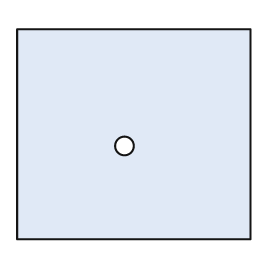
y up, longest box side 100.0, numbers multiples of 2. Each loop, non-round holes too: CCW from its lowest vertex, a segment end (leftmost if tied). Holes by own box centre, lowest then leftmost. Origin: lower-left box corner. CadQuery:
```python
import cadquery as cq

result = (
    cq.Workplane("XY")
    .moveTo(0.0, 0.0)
    .lineTo(100.0, 0.0)
    .lineTo(100.0, 90.0)
    .lineTo(0.0, 90.0)
    .close()
    .moveTo(46.0, 40.0)
    .circle(4.0)
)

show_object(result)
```